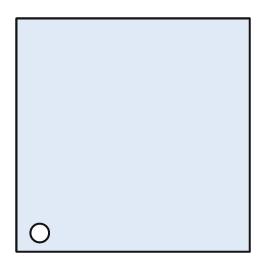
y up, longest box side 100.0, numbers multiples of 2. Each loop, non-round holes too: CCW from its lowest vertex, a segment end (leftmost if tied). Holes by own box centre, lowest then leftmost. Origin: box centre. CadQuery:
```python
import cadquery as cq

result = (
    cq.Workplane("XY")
    .moveTo(-50.0, -50.0)
    .lineTo(50.0, -50.0)
    .lineTo(50.0, 50.0)
    .lineTo(-50.0, 50.0)
    .close()
    .moveTo(-40.0, -42.0)
    .circle(4.0)
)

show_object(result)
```